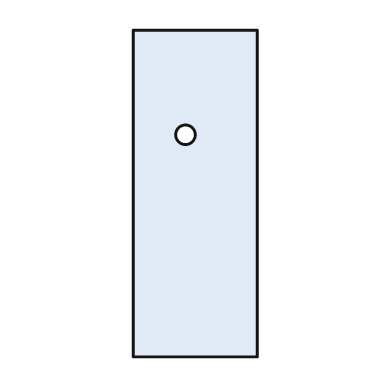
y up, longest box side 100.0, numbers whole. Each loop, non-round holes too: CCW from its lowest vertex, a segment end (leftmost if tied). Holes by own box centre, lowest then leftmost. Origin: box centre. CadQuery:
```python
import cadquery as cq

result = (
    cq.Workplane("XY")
    .moveTo(-19.0, -50.0)
    .lineTo(19.0, -50.0)
    .lineTo(19.0, 50.0)
    .lineTo(-19.0, 50.0)
    .close()
    .moveTo(-3.0, 18.0)
    .circle(3.0)
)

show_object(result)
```